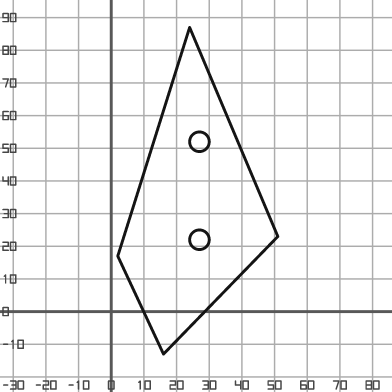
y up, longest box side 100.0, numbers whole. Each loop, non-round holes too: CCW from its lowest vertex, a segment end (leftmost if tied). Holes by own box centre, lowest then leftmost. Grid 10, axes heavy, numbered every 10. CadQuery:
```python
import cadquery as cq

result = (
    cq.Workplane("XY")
    .moveTo(16.0, -13.0)
    .lineTo(51.0, 23.0)
    .lineTo(24.0, 87.0)
    .lineTo(2.0, 17.0)
    .close()
    .moveTo(27.0, 22.0)
    .circle(3.0)
    .moveTo(27.0, 52.0)
    .circle(3.0)
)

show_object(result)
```